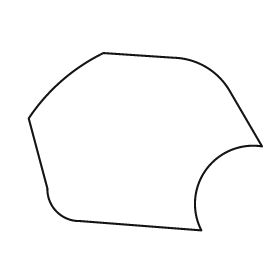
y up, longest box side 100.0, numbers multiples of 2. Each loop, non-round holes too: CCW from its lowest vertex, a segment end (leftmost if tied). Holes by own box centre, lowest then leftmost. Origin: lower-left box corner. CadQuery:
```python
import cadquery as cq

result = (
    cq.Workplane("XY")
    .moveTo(74.0, 0.0)
    .threePointArc((76.0, 26.0), (100.0, 36.0))
    .lineTo(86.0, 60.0)
    .threePointArc((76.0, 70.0), (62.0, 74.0))
    .lineTo(32.0, 76.0)
    .threePointArc((14.0, 64.0), (0.0, 48.0))
    .lineTo(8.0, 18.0)
    .threePointArc((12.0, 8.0), (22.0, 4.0))
    .close()
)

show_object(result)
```